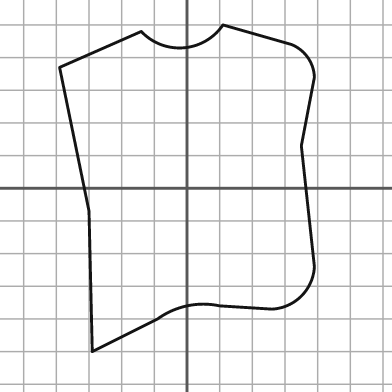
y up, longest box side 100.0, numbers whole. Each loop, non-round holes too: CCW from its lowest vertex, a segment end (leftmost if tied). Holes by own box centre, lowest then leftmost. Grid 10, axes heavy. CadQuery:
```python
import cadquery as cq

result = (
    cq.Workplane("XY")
    .moveTo(-29.0, -50.0)
    .lineTo(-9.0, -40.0)
    .threePointArc((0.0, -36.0), (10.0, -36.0))
    .lineTo(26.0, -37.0)
    .threePointArc((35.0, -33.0), (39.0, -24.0))
    .lineTo(35.0, 13.0)
    .lineTo(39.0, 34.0)
    .threePointArc((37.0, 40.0), (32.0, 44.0))
    .lineTo(11.0, 50.0)
    .threePointArc((-1.0, 43.0), (-14.0, 48.0))
    .lineTo(-39.0, 37.0)
    .lineTo(-30.0, -7.0)
    .close()
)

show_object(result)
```